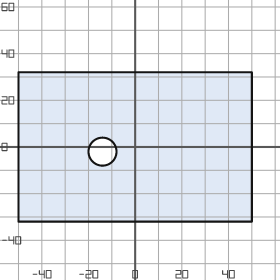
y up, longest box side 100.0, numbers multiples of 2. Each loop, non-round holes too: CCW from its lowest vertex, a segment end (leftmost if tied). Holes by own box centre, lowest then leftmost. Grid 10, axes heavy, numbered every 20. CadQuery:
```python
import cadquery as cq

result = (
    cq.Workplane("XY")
    .moveTo(-50.0, -32.0)
    .lineTo(50.0, -32.0)
    .lineTo(50.0, 32.0)
    .lineTo(-50.0, 32.0)
    .close()
    .moveTo(-14.0, -2.0)
    .circle(6.0)
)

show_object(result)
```